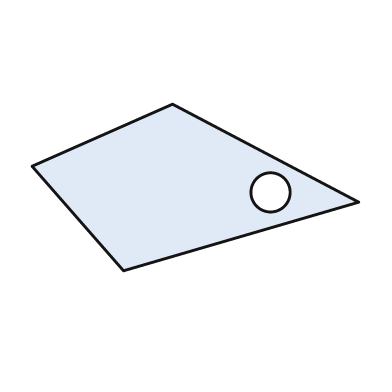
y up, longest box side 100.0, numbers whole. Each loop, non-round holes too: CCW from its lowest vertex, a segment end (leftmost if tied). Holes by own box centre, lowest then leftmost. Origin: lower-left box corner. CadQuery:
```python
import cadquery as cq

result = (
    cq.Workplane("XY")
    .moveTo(28.0, 0.0)
    .lineTo(100.0, 21.0)
    .lineTo(43.0, 51.0)
    .lineTo(0.0, 32.0)
    .close()
    .moveTo(73.0, 24.0)
    .circle(6.0)
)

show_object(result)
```